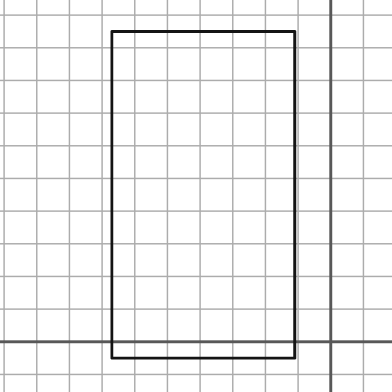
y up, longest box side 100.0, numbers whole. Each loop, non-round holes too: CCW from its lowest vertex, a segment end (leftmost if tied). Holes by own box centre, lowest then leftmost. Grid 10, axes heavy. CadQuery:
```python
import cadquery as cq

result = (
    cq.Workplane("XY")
    .moveTo(-67.0, -5.0)
    .lineTo(-11.0, -5.0)
    .lineTo(-11.0, 95.0)
    .lineTo(-67.0, 95.0)
    .close()
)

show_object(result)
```